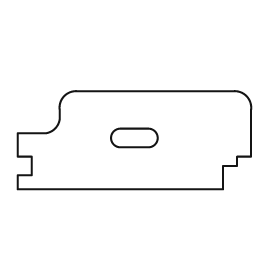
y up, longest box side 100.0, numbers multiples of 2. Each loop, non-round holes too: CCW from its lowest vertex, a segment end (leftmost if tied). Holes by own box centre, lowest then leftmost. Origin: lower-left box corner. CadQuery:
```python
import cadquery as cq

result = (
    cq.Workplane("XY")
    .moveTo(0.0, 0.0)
    .lineTo(88.0, 0.0)
    .lineTo(88.0, 10.0)
    .lineTo(94.0, 10.0)
    .lineTo(94.0, 14.0)
    .lineTo(100.0, 14.0)
    .lineTo(100.0, 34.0)
    .threePointArc((98.0, 40.0), (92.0, 42.0))
    .lineTo(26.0, 42.0)
    .threePointArc((20.0, 40.0), (18.0, 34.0))
    .lineTo(18.0, 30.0)
    .threePointArc((16.0, 26.0), (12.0, 24.0))
    .lineTo(0.0, 24.0)
    .lineTo(0.0, 14.0)
    .lineTo(6.0, 14.0)
    .lineTo(6.0, 6.0)
    .lineTo(0.0, 6.0)
    .close()
    .moveTo(44.0, 18.0)
    .lineTo(56.0, 18.0)
    .threePointArc((60.0, 22.0), (56.0, 26.0))
    .lineTo(44.0, 26.0)
    .threePointArc((40.0, 22.0), (44.0, 18.0))
    .close()
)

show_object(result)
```